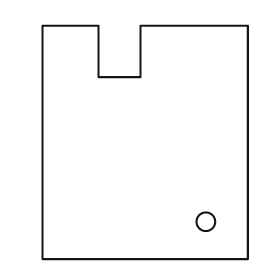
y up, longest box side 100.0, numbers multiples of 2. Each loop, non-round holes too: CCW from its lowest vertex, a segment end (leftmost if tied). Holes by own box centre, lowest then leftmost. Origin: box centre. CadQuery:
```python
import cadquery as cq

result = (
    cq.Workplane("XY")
    .moveTo(-44.0, -50.0)
    .lineTo(44.0, -50.0)
    .lineTo(44.0, 50.0)
    .lineTo(-2.0, 50.0)
    .lineTo(-2.0, 28.0)
    .lineTo(-20.0, 28.0)
    .lineTo(-20.0, 50.0)
    .lineTo(-44.0, 50.0)
    .close()
    .moveTo(26.0, -34.0)
    .circle(4.0)
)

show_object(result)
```